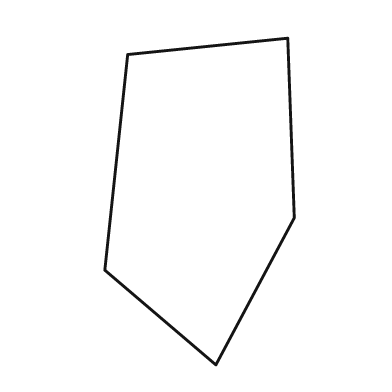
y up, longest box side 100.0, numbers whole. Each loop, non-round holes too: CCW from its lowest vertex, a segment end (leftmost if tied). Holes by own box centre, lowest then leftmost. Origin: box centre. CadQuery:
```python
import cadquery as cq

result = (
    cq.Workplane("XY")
    .moveTo(5.0, -50.0)
    .lineTo(29.0, -5.0)
    .lineTo(27.0, 50.0)
    .lineTo(-22.0, 45.0)
    .lineTo(-29.0, -21.0)
    .close()
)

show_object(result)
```